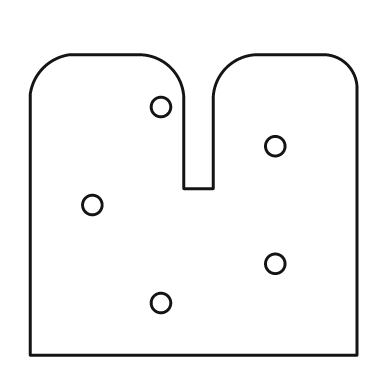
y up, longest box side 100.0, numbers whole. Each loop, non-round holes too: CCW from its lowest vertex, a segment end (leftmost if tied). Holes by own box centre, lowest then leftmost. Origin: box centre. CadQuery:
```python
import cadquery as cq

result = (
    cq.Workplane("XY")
    .moveTo(-50.0, -46.0)
    .lineTo(50.0, -46.0)
    .lineTo(50.0, 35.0)
    .threePointArc((47.0, 43.0), (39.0, 46.0))
    .lineTo(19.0, 46.0)
    .threePointArc((10.0, 42.0), (6.0, 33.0))
    .lineTo(6.0, 5.0)
    .lineTo(-3.0, 5.0)
    .lineTo(-3.0, 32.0)
    .threePointArc((-7.0, 42.0), (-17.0, 46.0))
    .lineTo(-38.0, 46.0)
    .threePointArc((-46.0, 42.0), (-50.0, 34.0))
    .close()
    .moveTo(-10.0, -30.0)
    .circle(3.0)
    .moveTo(25.0, -18.0)
    .circle(3.0)
    .moveTo(-31.0, 0.0)
    .circle(3.0)
    .moveTo(25.0, 18.0)
    .circle(3.0)
    .moveTo(-10.0, 30.0)
    .circle(3.0)
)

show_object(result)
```